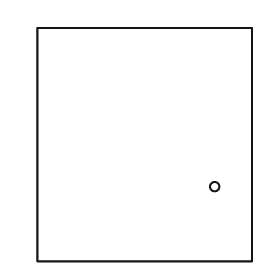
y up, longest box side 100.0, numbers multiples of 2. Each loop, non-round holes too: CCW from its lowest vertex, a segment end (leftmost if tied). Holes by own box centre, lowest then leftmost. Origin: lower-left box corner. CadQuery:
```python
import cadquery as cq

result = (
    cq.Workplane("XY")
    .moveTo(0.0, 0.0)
    .lineTo(92.0, 0.0)
    .lineTo(92.0, 100.0)
    .lineTo(0.0, 100.0)
    .close()
    .moveTo(76.0, 32.0)
    .circle(2.0)
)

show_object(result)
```